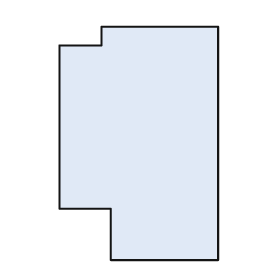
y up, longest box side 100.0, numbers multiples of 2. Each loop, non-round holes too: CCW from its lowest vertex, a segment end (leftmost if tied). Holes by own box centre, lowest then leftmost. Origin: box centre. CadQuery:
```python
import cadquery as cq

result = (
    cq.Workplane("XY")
    .moveTo(-12.0, -50.0)
    .lineTo(34.0, -50.0)
    .lineTo(34.0, 50.0)
    .lineTo(-16.0, 50.0)
    .lineTo(-16.0, 42.0)
    .lineTo(-34.0, 42.0)
    .lineTo(-34.0, -28.0)
    .lineTo(-12.0, -28.0)
    .close()
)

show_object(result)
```